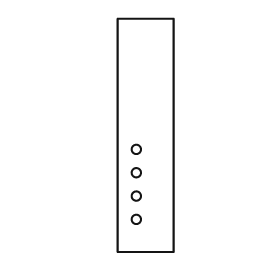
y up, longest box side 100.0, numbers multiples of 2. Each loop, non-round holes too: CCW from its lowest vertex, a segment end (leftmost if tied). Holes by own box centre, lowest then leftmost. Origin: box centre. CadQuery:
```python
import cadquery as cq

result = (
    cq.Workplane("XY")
    .moveTo(-12.0, -50.0)
    .lineTo(12.0, -50.0)
    .lineTo(12.0, 50.0)
    .lineTo(-12.0, 50.0)
    .close()
    .moveTo(-4.0, -36.0)
    .circle(2.0)
    .moveTo(-4.0, -26.0)
    .circle(2.0)
    .moveTo(-4.0, -16.0)
    .circle(2.0)
    .moveTo(-4.0, -6.0)
    .circle(2.0)
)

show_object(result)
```